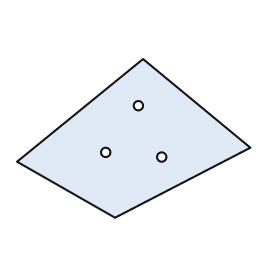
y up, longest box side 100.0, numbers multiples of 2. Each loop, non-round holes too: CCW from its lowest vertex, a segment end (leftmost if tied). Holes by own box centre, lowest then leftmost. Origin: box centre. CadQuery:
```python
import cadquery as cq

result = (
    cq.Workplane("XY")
    .moveTo(-8.0, -34.0)
    .lineTo(50.0, -4.0)
    .lineTo(4.0, 34.0)
    .lineTo(-50.0, -10.0)
    .close()
    .moveTo(12.0, -8.0)
    .circle(2.0)
    .moveTo(-12.0, -6.0)
    .circle(2.0)
    .moveTo(2.0, 14.0)
    .circle(2.0)
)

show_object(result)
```